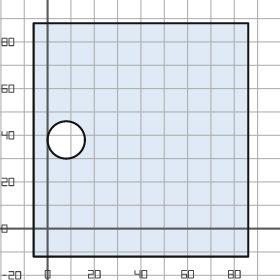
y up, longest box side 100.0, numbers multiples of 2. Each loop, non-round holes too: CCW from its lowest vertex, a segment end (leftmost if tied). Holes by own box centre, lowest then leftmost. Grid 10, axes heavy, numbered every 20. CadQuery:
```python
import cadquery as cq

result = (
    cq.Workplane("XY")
    .moveTo(-6.0, -12.0)
    .lineTo(86.0, -12.0)
    .lineTo(86.0, 88.0)
    .lineTo(-6.0, 88.0)
    .close()
    .moveTo(8.0, 38.0)
    .circle(8.0)
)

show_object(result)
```